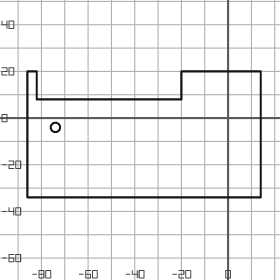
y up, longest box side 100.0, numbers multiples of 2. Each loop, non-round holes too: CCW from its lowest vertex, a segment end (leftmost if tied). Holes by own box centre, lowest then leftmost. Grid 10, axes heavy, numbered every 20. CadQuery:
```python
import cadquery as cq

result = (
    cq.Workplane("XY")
    .moveTo(-86.0, -34.0)
    .lineTo(14.0, -34.0)
    .lineTo(14.0, 20.0)
    .lineTo(-20.0, 20.0)
    .lineTo(-20.0, 8.0)
    .lineTo(-82.0, 8.0)
    .lineTo(-82.0, 20.0)
    .lineTo(-86.0, 20.0)
    .close()
    .moveTo(-74.0, -4.0)
    .circle(2.0)
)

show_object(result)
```